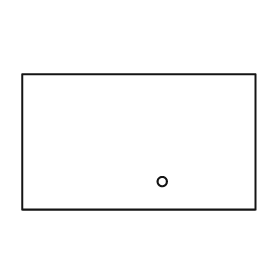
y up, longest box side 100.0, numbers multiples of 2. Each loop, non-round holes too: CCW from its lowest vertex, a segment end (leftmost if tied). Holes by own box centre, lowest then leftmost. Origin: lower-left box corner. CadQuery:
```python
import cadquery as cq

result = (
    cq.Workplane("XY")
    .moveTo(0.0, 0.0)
    .lineTo(100.0, 0.0)
    .lineTo(100.0, 58.0)
    .lineTo(0.0, 58.0)
    .close()
    .moveTo(60.0, 12.0)
    .circle(2.0)
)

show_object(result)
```